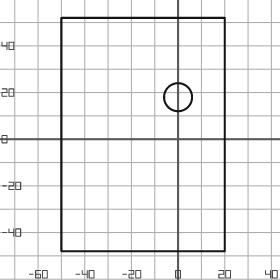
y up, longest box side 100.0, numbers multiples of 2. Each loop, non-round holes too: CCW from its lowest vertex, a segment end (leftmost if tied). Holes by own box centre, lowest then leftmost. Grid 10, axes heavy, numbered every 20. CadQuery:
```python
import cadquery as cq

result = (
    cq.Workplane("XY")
    .moveTo(-50.0, -48.0)
    .lineTo(20.0, -48.0)
    .lineTo(20.0, 52.0)
    .lineTo(-50.0, 52.0)
    .close()
    .moveTo(0.0, 18.0)
    .circle(6.0)
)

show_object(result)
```